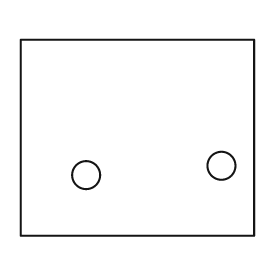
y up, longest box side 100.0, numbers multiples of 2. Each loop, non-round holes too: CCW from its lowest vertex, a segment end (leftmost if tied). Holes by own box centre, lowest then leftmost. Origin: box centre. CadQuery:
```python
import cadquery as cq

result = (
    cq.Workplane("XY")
    .moveTo(-50.0, -42.0)
    .lineTo(50.0, -42.0)
    .lineTo(50.0, 42.0)
    .lineTo(-50.0, 42.0)
    .close()
    .moveTo(-22.0, -16.0)
    .circle(6.0)
    .moveTo(36.0, -12.0)
    .circle(6.0)
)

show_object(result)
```